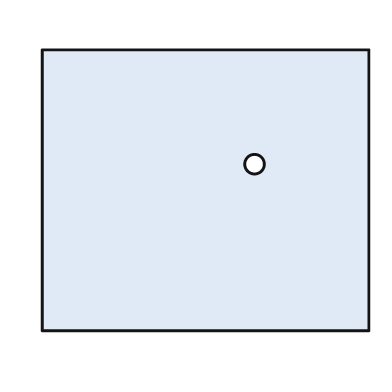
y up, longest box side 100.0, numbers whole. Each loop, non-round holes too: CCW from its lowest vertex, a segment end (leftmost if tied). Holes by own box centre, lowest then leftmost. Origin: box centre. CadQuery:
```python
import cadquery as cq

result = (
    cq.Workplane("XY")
    .moveTo(-50.0, -43.0)
    .lineTo(50.0, -43.0)
    .lineTo(50.0, 43.0)
    .lineTo(-50.0, 43.0)
    .close()
    .moveTo(15.0, 8.0)
    .circle(3.0)
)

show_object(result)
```